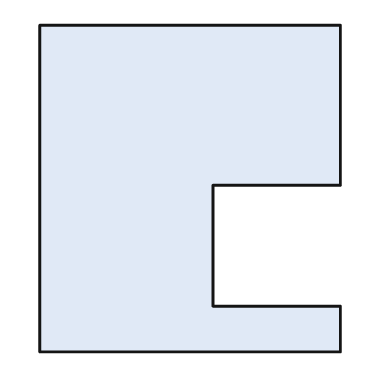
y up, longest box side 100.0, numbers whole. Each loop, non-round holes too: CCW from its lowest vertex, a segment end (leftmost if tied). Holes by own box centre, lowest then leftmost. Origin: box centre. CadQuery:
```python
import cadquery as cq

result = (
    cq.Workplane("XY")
    .moveTo(-46.0, -50.0)
    .lineTo(46.0, -50.0)
    .lineTo(46.0, -36.0)
    .lineTo(7.0, -36.0)
    .lineTo(7.0, 1.0)
    .lineTo(46.0, 1.0)
    .lineTo(46.0, 50.0)
    .lineTo(-46.0, 50.0)
    .close()
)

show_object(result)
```